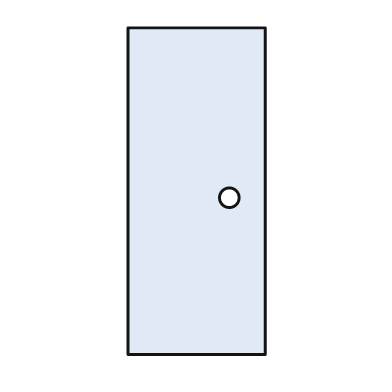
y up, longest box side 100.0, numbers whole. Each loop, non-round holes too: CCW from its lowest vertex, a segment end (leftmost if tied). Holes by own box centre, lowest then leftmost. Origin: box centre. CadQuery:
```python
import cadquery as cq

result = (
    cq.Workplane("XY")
    .moveTo(-21.0, -50.0)
    .lineTo(21.0, -50.0)
    .lineTo(21.0, 50.0)
    .lineTo(-21.0, 50.0)
    .close()
    .moveTo(10.0, -2.0)
    .circle(3.0)
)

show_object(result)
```